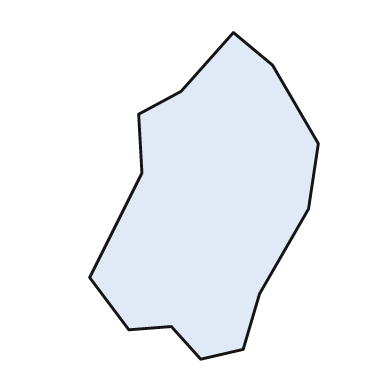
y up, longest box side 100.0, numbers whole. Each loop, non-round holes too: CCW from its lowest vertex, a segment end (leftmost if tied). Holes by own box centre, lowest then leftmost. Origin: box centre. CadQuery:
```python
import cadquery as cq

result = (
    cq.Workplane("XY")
    .moveTo(-1.0, -50.0)
    .lineTo(12.0, -47.0)
    .lineTo(17.0, -30.0)
    .lineTo(32.0, -4.0)
    .lineTo(35.0, 16.0)
    .lineTo(21.0, 40.0)
    .lineTo(9.0, 50.0)
    .lineTo(-7.0, 32.0)
    .lineTo(-20.0, 25.0)
    .lineTo(-19.0, 7.0)
    .lineTo(-35.0, -25.0)
    .lineTo(-23.0, -41.0)
    .lineTo(-10.0, -40.0)
    .close()
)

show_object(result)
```